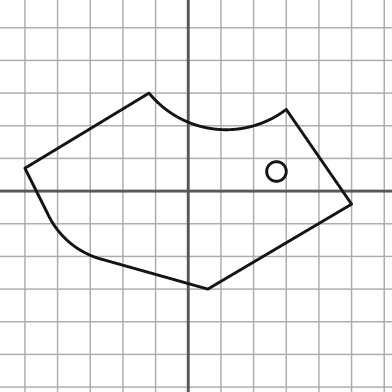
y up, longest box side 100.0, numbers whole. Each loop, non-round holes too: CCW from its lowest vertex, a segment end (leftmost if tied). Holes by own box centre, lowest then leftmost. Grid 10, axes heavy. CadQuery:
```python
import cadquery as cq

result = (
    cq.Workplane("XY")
    .moveTo(6.0, -30.0)
    .lineTo(50.0, -4.0)
    .lineTo(30.0, 25.0)
    .threePointArc((8.0, 19.0), (-12.0, 30.0))
    .lineTo(-50.0, 7.0)
    .lineTo(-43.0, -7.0)
    .threePointArc((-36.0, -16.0), (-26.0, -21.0))
    .close()
    .moveTo(27.0, 6.0)
    .circle(3.0)
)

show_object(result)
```